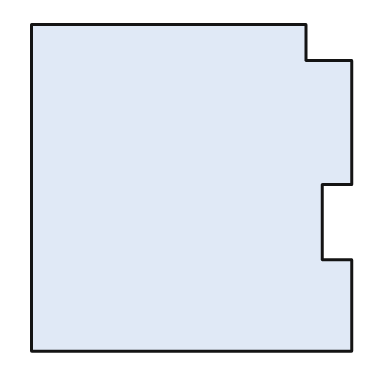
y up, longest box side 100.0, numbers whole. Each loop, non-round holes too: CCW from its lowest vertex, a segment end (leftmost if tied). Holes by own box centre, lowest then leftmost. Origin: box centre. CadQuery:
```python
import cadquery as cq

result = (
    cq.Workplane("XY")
    .moveTo(-49.0, -50.0)
    .lineTo(49.0, -50.0)
    .lineTo(49.0, -22.0)
    .lineTo(40.0, -22.0)
    .lineTo(40.0, 1.0)
    .lineTo(49.0, 1.0)
    .lineTo(49.0, 39.0)
    .lineTo(35.0, 39.0)
    .lineTo(35.0, 50.0)
    .lineTo(-49.0, 50.0)
    .close()
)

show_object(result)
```